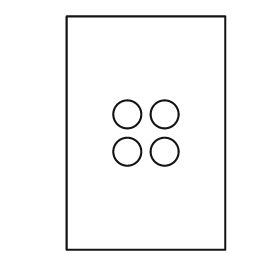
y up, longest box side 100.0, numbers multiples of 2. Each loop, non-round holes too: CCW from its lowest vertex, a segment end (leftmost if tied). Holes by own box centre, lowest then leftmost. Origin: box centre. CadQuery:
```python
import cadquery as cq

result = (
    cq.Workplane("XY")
    .moveTo(-34.0, -50.0)
    .lineTo(34.0, -50.0)
    .lineTo(34.0, 50.0)
    .lineTo(-34.0, 50.0)
    .close()
    .moveTo(-8.0, -8.0)
    .circle(6.0)
    .moveTo(8.0, -8.0)
    .circle(6.0)
    .moveTo(-8.0, 8.0)
    .circle(6.0)
    .moveTo(8.0, 8.0)
    .circle(6.0)
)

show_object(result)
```